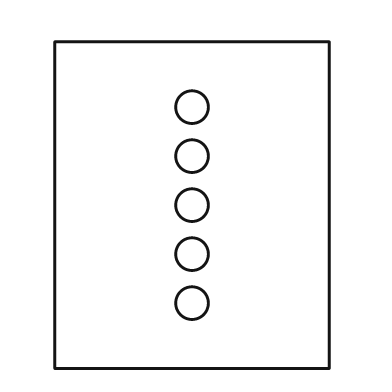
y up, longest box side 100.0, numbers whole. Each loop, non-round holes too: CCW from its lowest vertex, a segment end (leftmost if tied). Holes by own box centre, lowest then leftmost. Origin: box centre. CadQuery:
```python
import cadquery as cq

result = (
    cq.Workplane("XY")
    .moveTo(-42.0, -50.0)
    .lineTo(42.0, -50.0)
    .lineTo(42.0, 50.0)
    .lineTo(-42.0, 50.0)
    .close()
    .moveTo(0.0, -30.0)
    .circle(5.0)
    .moveTo(0.0, -15.0)
    .circle(5.0)
    .moveTo(0.0, 0.0)
    .circle(5.0)
    .moveTo(0.0, 15.0)
    .circle(5.0)
    .moveTo(0.0, 30.0)
    .circle(5.0)
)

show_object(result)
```